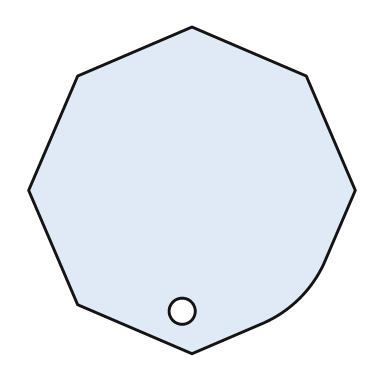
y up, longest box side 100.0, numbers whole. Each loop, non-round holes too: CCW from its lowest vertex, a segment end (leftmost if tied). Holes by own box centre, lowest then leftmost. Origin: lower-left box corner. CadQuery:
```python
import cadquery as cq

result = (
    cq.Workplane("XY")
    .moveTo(50.0, 0.0)
    .lineTo(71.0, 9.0)
    .threePointArc((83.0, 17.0), (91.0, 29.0))
    .lineTo(100.0, 50.0)
    .lineTo(85.0, 85.0)
    .lineTo(50.0, 100.0)
    .lineTo(15.0, 85.0)
    .lineTo(0.0, 50.0)
    .lineTo(15.0, 15.0)
    .close()
    .moveTo(47.0, 13.0)
    .circle(4.0)
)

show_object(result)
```